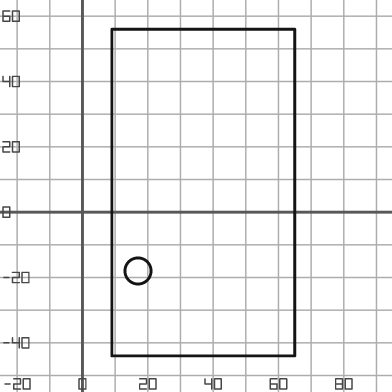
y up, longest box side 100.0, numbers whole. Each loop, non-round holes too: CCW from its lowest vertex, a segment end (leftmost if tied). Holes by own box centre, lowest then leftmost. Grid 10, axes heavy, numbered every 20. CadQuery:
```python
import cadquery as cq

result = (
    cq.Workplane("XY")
    .moveTo(9.0, -44.0)
    .lineTo(65.0, -44.0)
    .lineTo(65.0, 56.0)
    .lineTo(9.0, 56.0)
    .close()
    .moveTo(17.0, -18.0)
    .circle(4.0)
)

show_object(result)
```